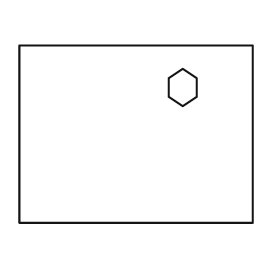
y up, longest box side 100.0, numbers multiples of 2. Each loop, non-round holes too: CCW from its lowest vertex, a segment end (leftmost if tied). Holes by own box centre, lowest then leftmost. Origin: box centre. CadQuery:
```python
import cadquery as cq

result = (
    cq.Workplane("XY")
    .moveTo(-50.0, -38.0)
    .lineTo(50.0, -38.0)
    .lineTo(50.0, 38.0)
    .lineTo(-50.0, 38.0)
    .close()
    .moveTo(20.0, 12.0)
    .lineTo(26.0, 16.0)
    .lineTo(26.0, 24.0)
    .lineTo(20.0, 28.0)
    .lineTo(14.0, 24.0)
    .lineTo(14.0, 16.0)
    .close()
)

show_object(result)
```